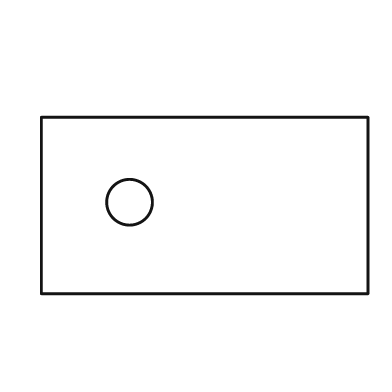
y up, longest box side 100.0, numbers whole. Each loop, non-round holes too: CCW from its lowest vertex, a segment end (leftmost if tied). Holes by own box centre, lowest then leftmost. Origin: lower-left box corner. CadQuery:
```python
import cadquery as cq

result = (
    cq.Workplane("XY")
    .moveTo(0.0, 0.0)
    .lineTo(100.0, 0.0)
    .lineTo(100.0, 54.0)
    .lineTo(0.0, 54.0)
    .close()
    .moveTo(27.0, 28.0)
    .circle(7.0)
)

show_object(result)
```